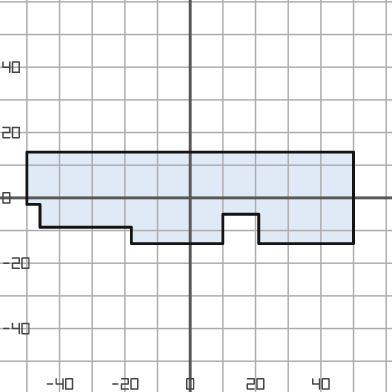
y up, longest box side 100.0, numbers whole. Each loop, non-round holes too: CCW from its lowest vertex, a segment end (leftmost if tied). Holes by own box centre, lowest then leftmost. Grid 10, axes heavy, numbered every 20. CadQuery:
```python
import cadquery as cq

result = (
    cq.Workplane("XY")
    .moveTo(-18.0, -14.0)
    .lineTo(10.0, -14.0)
    .lineTo(10.0, -5.0)
    .lineTo(21.0, -5.0)
    .lineTo(21.0, -14.0)
    .lineTo(50.0, -14.0)
    .lineTo(50.0, 14.0)
    .lineTo(-50.0, 14.0)
    .lineTo(-50.0, -2.0)
    .lineTo(-46.0, -2.0)
    .lineTo(-46.0, -9.0)
    .lineTo(-18.0, -9.0)
    .close()
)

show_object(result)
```